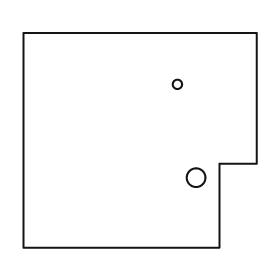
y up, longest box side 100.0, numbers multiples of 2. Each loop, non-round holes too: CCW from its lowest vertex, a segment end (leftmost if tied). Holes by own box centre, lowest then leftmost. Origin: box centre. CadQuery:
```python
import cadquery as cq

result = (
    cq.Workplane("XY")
    .moveTo(-50.0, -46.0)
    .lineTo(34.0, -46.0)
    .lineTo(34.0, -10.0)
    .lineTo(50.0, -10.0)
    .lineTo(50.0, 46.0)
    .lineTo(-50.0, 46.0)
    .close()
    .moveTo(24.0, -16.0)
    .circle(4.0)
    .moveTo(16.0, 24.0)
    .circle(2.0)
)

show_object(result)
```